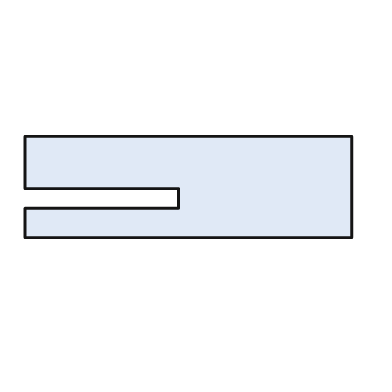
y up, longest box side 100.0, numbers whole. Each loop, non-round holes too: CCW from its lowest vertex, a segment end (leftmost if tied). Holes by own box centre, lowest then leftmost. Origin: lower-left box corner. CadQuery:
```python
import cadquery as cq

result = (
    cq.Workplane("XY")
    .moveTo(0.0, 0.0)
    .lineTo(100.0, 0.0)
    .lineTo(100.0, 31.0)
    .lineTo(0.0, 31.0)
    .lineTo(0.0, 15.0)
    .lineTo(47.0, 15.0)
    .lineTo(47.0, 9.0)
    .lineTo(0.0, 9.0)
    .close()
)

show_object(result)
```